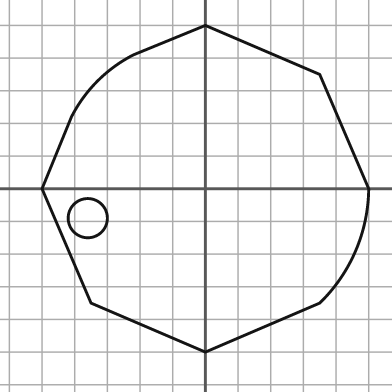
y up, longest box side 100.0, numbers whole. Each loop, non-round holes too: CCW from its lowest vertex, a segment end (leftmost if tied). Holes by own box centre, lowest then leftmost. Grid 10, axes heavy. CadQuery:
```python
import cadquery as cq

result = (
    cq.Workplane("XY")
    .moveTo(0.0, -50.0)
    .lineTo(35.0, -35.0)
    .threePointArc((46.0, -19.0), (50.0, 0.0))
    .lineTo(35.0, 35.0)
    .lineTo(0.0, 50.0)
    .lineTo(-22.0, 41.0)
    .threePointArc((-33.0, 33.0), (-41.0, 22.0))
    .lineTo(-50.0, 0.0)
    .lineTo(-35.0, -35.0)
    .close()
    .moveTo(-36.0, -9.0)
    .circle(6.0)
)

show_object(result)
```